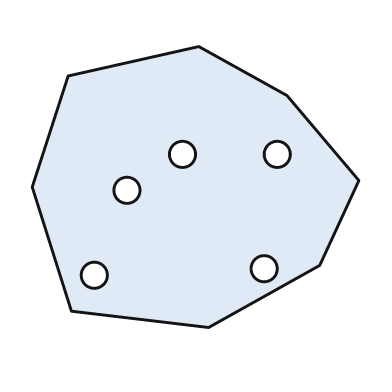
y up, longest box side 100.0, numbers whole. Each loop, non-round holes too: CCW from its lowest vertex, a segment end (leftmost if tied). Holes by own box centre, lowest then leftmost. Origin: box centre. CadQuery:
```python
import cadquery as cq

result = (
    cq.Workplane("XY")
    .moveTo(4.0, -43.0)
    .lineTo(38.0, -24.0)
    .lineTo(50.0, 2.0)
    .lineTo(28.0, 28.0)
    .lineTo(1.0, 43.0)
    .lineTo(-39.0, 34.0)
    .lineTo(-50.0, 0.0)
    .lineTo(-38.0, -38.0)
    .close()
    .moveTo(-31.0, -27.0)
    .circle(4.0)
    .moveTo(21.0, -25.0)
    .circle(4.0)
    .moveTo(-21.0, -1.0)
    .circle(4.0)
    .moveTo(-4.0, 10.0)
    .circle(4.0)
    .moveTo(25.0, 10.0)
    .circle(4.0)
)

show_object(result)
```